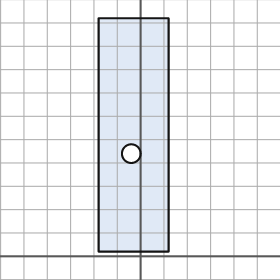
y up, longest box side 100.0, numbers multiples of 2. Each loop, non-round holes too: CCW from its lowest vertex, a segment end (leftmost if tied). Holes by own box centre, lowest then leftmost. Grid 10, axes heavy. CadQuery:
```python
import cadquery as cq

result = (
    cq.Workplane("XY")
    .moveTo(-18.0, 2.0)
    .lineTo(12.0, 2.0)
    .lineTo(12.0, 102.0)
    .lineTo(-18.0, 102.0)
    .close()
    .moveTo(-4.0, 44.0)
    .circle(4.0)
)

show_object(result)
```